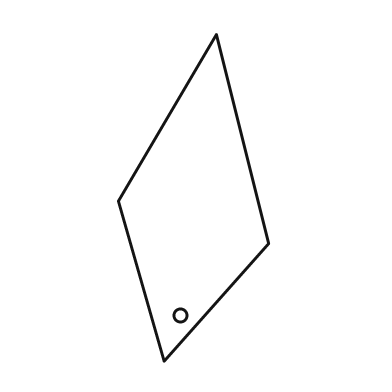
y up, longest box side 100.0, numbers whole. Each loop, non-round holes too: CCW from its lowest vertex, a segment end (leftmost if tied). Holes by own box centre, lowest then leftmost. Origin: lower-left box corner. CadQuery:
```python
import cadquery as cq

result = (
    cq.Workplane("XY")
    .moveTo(14.0, 0.0)
    .lineTo(46.0, 36.0)
    .lineTo(30.0, 100.0)
    .lineTo(0.0, 49.0)
    .close()
    .moveTo(19.0, 14.0)
    .circle(2.0)
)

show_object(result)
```